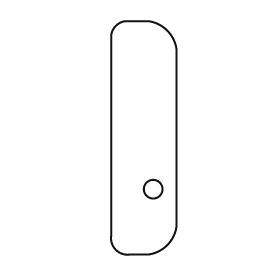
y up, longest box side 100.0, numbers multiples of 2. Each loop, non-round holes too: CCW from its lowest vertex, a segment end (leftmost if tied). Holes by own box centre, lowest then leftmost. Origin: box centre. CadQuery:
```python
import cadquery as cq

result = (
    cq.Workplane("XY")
    .moveTo(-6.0, -50.0)
    .lineTo(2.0, -50.0)
    .threePointArc((10.0, -46.0), (14.0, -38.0))
    .lineTo(14.0, 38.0)
    .threePointArc((10.0, 46.0), (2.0, 50.0))
    .lineTo(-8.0, 50.0)
    .threePointArc((-12.0, 48.0), (-14.0, 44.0))
    .lineTo(-14.0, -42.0)
    .threePointArc((-12.0, -48.0), (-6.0, -50.0))
    .close()
    .moveTo(4.0, -22.0)
    .circle(4.0)
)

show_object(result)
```